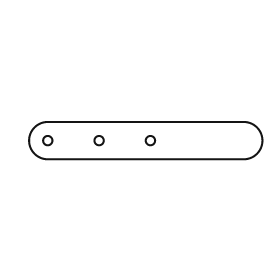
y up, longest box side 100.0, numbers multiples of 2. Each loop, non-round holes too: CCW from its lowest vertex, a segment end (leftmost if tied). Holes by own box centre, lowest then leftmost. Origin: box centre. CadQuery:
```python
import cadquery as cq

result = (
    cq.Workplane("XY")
    .moveTo(-42.0, -8.0)
    .lineTo(42.0, -8.0)
    .threePointArc((50.0, 0.0), (42.0, 8.0))
    .lineTo(-42.0, 8.0)
    .threePointArc((-50.0, 0.0), (-42.0, -8.0))
    .close()
    .moveTo(-42.0, 0.0)
    .circle(2.0)
    .moveTo(-20.0, 0.0)
    .circle(2.0)
    .moveTo(2.0, 0.0)
    .circle(2.0)
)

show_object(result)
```